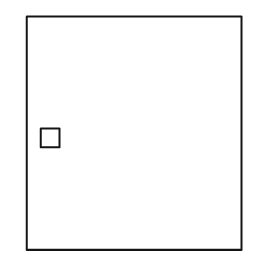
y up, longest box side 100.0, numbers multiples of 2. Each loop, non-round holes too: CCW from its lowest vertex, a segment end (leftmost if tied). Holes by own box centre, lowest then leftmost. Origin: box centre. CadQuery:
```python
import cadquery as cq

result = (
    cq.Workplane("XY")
    .moveTo(-46.0, -50.0)
    .lineTo(46.0, -50.0)
    .lineTo(46.0, 50.0)
    .lineTo(-46.0, 50.0)
    .close()
    .moveTo(-40.0, -6.0)
    .lineTo(-32.0, -6.0)
    .lineTo(-32.0, 2.0)
    .lineTo(-40.0, 2.0)
    .close()
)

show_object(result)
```